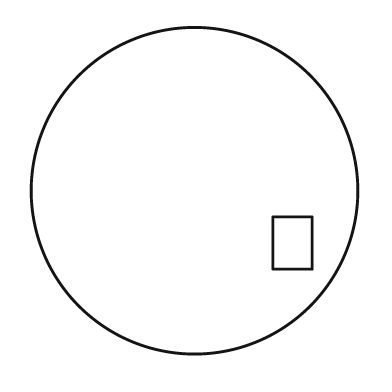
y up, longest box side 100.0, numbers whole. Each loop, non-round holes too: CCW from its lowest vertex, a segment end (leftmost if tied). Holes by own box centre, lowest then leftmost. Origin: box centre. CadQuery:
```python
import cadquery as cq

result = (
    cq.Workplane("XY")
    .moveTo(0.0, 0.0)
    .circle(50.0)
    .moveTo(24.0, -24.0)
    .lineTo(36.0, -24.0)
    .lineTo(36.0, -8.0)
    .lineTo(24.0, -8.0)
    .close()
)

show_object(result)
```